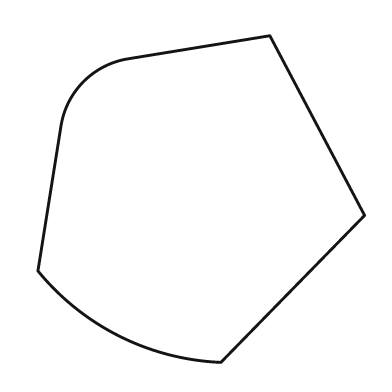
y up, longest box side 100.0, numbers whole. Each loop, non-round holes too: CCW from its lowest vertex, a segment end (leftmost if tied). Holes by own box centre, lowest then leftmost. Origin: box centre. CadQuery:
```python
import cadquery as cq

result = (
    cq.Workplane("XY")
    .moveTo(6.0, -50.0)
    .lineTo(50.0, -5.0)
    .lineTo(21.0, 50.0)
    .lineTo(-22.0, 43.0)
    .threePointArc((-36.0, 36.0), (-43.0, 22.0))
    .lineTo(-50.0, -22.0)
    .threePointArc((-25.0, -42.0), (6.0, -50.0))
    .close()
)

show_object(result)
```